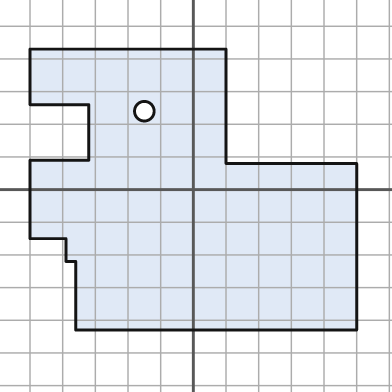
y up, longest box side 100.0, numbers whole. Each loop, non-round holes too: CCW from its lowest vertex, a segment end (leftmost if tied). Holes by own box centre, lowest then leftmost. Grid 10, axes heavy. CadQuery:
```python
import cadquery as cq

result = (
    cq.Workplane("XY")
    .moveTo(-36.0, -43.0)
    .lineTo(50.0, -43.0)
    .lineTo(50.0, 8.0)
    .lineTo(10.0, 8.0)
    .lineTo(10.0, 43.0)
    .lineTo(-50.0, 43.0)
    .lineTo(-50.0, 26.0)
    .lineTo(-32.0, 26.0)
    .lineTo(-32.0, 9.0)
    .lineTo(-50.0, 9.0)
    .lineTo(-50.0, -15.0)
    .lineTo(-39.0, -15.0)
    .lineTo(-39.0, -22.0)
    .lineTo(-36.0, -22.0)
    .close()
    .moveTo(-15.0, 24.0)
    .circle(3.0)
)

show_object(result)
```